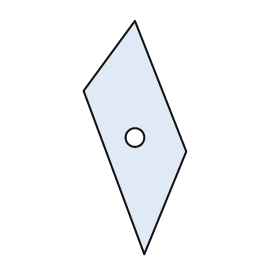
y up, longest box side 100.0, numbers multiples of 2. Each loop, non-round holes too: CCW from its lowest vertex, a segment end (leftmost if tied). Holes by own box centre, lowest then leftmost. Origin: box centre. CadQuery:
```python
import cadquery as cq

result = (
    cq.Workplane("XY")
    .moveTo(4.0, -50.0)
    .lineTo(22.0, -6.0)
    .lineTo(0.0, 50.0)
    .lineTo(-22.0, 20.0)
    .close()
    .moveTo(0.0, 0.0)
    .circle(4.0)
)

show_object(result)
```